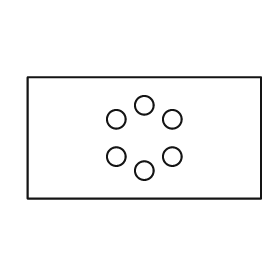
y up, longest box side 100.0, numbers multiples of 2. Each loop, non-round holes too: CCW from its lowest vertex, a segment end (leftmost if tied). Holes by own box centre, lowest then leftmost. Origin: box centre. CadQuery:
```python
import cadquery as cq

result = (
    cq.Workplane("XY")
    .moveTo(-50.0, -26.0)
    .lineTo(50.0, -26.0)
    .lineTo(50.0, 26.0)
    .lineTo(-50.0, 26.0)
    .close()
    .moveTo(0.0, -14.0)
    .circle(4.0)
    .moveTo(-12.0, -8.0)
    .circle(4.0)
    .moveTo(12.0, -8.0)
    .circle(4.0)
    .moveTo(-12.0, 8.0)
    .circle(4.0)
    .moveTo(12.0, 8.0)
    .circle(4.0)
    .moveTo(0.0, 14.0)
    .circle(4.0)
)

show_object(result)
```